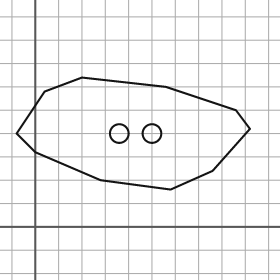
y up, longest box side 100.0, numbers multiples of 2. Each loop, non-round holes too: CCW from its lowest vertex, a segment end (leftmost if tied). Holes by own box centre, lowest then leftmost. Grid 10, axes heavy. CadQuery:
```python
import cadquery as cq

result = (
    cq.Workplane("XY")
    .moveTo(58.0, 16.0)
    .lineTo(76.0, 24.0)
    .lineTo(92.0, 42.0)
    .lineTo(86.0, 50.0)
    .lineTo(56.0, 60.0)
    .lineTo(20.0, 64.0)
    .lineTo(4.0, 58.0)
    .lineTo(-8.0, 40.0)
    .lineTo(0.0, 32.0)
    .lineTo(28.0, 20.0)
    .close()
    .moveTo(36.0, 40.0)
    .circle(4.0)
    .moveTo(50.0, 40.0)
    .circle(4.0)
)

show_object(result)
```